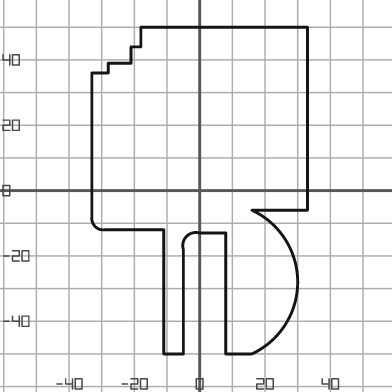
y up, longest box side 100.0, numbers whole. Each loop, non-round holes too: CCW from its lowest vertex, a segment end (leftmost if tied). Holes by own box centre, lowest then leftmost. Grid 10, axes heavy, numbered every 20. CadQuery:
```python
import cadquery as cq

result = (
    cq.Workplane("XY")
    .moveTo(-11.0, -50.0)
    .lineTo(-5.0, -50.0)
    .lineTo(-5.0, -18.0)
    .threePointArc((-4.0, -14.0), (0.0, -13.0))
    .lineTo(8.0, -13.0)
    .lineTo(8.0, -50.0)
    .lineTo(16.0, -50.0)
    .threePointArc((30.0, -28.0), (16.0, -6.0))
    .lineTo(33.0, -6.0)
    .lineTo(33.0, 50.0)
    .lineTo(-18.0, 50.0)
    .lineTo(-18.0, 44.0)
    .lineTo(-21.0, 44.0)
    .lineTo(-21.0, 39.0)
    .lineTo(-28.0, 39.0)
    .lineTo(-28.0, 36.0)
    .lineTo(-33.0, 36.0)
    .lineTo(-33.0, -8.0)
    .threePointArc((-32.0, -11.0), (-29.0, -12.0))
    .lineTo(-11.0, -12.0)
    .close()
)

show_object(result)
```